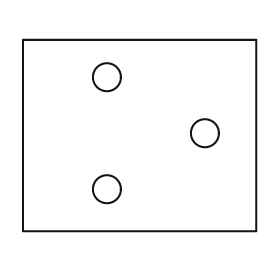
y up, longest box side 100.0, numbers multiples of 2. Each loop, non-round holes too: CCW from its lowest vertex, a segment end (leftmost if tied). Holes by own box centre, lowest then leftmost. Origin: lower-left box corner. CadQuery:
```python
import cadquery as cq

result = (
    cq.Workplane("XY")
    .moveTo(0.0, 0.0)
    .lineTo(100.0, 0.0)
    .lineTo(100.0, 82.0)
    .lineTo(0.0, 82.0)
    .close()
    .moveTo(36.0, 18.0)
    .circle(6.0)
    .moveTo(78.0, 42.0)
    .circle(6.0)
    .moveTo(36.0, 66.0)
    .circle(6.0)
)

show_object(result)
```